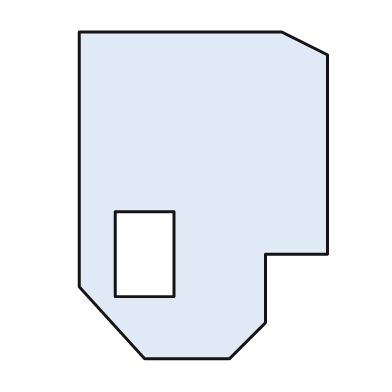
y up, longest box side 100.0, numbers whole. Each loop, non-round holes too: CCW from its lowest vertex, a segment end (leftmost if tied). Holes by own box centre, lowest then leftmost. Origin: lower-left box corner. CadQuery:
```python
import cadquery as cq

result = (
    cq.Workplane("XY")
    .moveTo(20.0, 0.0)
    .lineTo(46.0, 0.0)
    .lineTo(57.0, 11.0)
    .lineTo(57.0, 32.0)
    .lineTo(76.0, 32.0)
    .lineTo(76.0, 93.0)
    .lineTo(62.0, 100.0)
    .lineTo(0.0, 100.0)
    .lineTo(0.0, 22.0)
    .close()
    .moveTo(11.0, 19.0)
    .lineTo(29.0, 19.0)
    .lineTo(29.0, 45.0)
    .lineTo(11.0, 45.0)
    .close()
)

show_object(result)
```